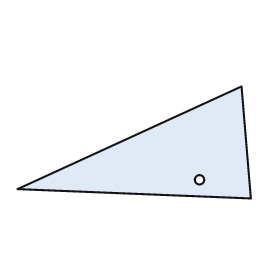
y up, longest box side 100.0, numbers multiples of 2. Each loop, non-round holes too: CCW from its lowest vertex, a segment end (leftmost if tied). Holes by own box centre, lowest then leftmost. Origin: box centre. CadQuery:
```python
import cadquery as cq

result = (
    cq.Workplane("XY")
    .moveTo(50.0, -24.0)
    .lineTo(46.0, 24.0)
    .lineTo(-50.0, -20.0)
    .close()
    .moveTo(28.0, -16.0)
    .circle(2.0)
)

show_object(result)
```